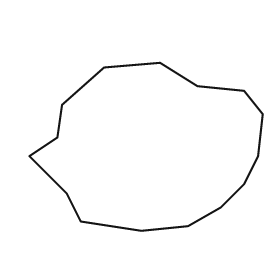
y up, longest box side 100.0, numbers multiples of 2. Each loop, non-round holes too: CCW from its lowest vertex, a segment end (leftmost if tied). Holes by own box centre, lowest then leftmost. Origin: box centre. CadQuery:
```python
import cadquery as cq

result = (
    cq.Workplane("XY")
    .moveTo(-2.0, -36.0)
    .lineTo(18.0, -34.0)
    .lineTo(32.0, -26.0)
    .lineTo(42.0, -16.0)
    .lineTo(48.0, -4.0)
    .lineTo(50.0, 14.0)
    .lineTo(42.0, 24.0)
    .lineTo(22.0, 26.0)
    .lineTo(6.0, 36.0)
    .lineTo(-18.0, 34.0)
    .lineTo(-36.0, 18.0)
    .lineTo(-38.0, 4.0)
    .lineTo(-50.0, -4.0)
    .lineTo(-34.0, -20.0)
    .lineTo(-28.0, -32.0)
    .close()
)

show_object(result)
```